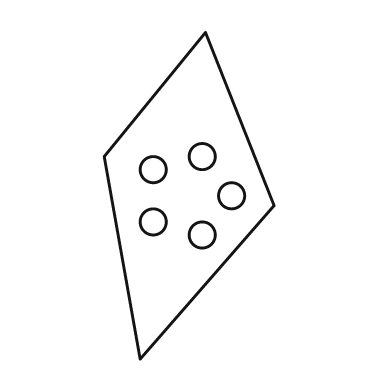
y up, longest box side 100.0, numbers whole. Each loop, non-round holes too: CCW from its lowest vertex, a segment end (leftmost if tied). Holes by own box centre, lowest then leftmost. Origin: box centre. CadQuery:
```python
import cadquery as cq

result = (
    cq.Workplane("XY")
    .moveTo(-15.0, -50.0)
    .lineTo(26.0, -3.0)
    .lineTo(5.0, 50.0)
    .lineTo(-26.0, 12.0)
    .close()
    .moveTo(4.0, -12.0)
    .circle(4.0)
    .moveTo(-11.0, -8.0)
    .circle(4.0)
    .moveTo(13.0, 0.0)
    .circle(4.0)
    .moveTo(-11.0, 8.0)
    .circle(4.0)
    .moveTo(4.0, 12.0)
    .circle(4.0)
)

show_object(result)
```